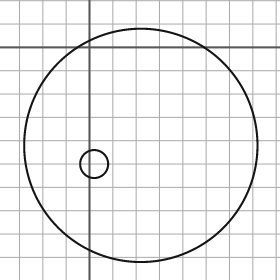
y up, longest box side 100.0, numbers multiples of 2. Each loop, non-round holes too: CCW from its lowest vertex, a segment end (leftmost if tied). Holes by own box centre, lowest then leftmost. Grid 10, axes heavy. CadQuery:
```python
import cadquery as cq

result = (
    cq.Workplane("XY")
    .moveTo(22.0, -42.0)
    .circle(50.0)
    .moveTo(2.0, -50.0)
    .circle(6.0)
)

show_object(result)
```